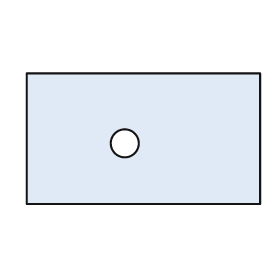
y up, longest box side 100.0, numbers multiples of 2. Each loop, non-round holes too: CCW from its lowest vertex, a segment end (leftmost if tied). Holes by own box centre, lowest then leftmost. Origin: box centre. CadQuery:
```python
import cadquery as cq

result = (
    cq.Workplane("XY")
    .moveTo(-50.0, -28.0)
    .lineTo(50.0, -28.0)
    .lineTo(50.0, 28.0)
    .lineTo(-50.0, 28.0)
    .close()
    .moveTo(-8.0, -2.0)
    .circle(6.0)
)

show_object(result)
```